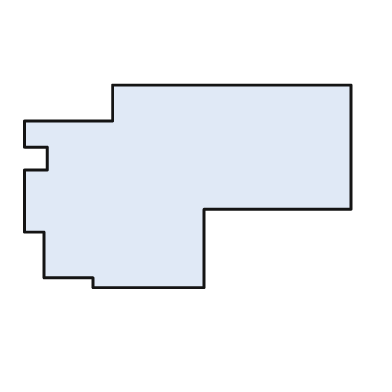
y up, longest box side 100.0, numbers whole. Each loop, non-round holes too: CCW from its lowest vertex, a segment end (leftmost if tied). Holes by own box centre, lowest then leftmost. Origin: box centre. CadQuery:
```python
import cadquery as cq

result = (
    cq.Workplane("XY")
    .moveTo(-29.0, -31.0)
    .lineTo(5.0, -31.0)
    .lineTo(5.0, -7.0)
    .lineTo(50.0, -7.0)
    .lineTo(50.0, 31.0)
    .lineTo(-23.0, 31.0)
    .lineTo(-23.0, 20.0)
    .lineTo(-50.0, 20.0)
    .lineTo(-50.0, 12.0)
    .lineTo(-43.0, 12.0)
    .lineTo(-43.0, 5.0)
    .lineTo(-50.0, 5.0)
    .lineTo(-50.0, -14.0)
    .lineTo(-44.0, -14.0)
    .lineTo(-44.0, -28.0)
    .lineTo(-29.0, -28.0)
    .close()
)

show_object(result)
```